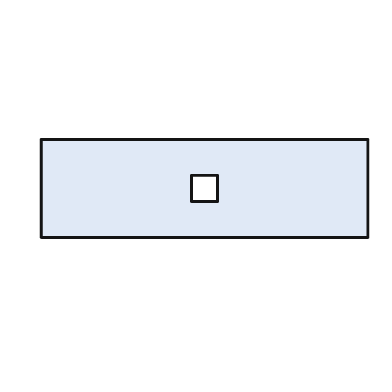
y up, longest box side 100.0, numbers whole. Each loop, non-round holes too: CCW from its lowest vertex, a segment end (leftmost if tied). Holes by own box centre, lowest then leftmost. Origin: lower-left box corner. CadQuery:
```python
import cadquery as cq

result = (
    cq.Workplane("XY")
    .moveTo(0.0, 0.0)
    .lineTo(100.0, 0.0)
    .lineTo(100.0, 30.0)
    .lineTo(0.0, 30.0)
    .close()
    .moveTo(46.0, 11.0)
    .lineTo(54.0, 11.0)
    .lineTo(54.0, 19.0)
    .lineTo(46.0, 19.0)
    .close()
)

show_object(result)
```